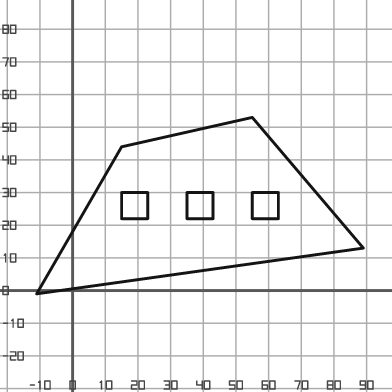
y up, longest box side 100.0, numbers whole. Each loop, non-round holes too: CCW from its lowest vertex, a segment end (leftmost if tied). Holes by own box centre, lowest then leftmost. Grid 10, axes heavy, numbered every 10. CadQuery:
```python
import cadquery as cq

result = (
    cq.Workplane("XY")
    .moveTo(-11.0, -1.0)
    .lineTo(89.0, 13.0)
    .lineTo(55.0, 53.0)
    .lineTo(15.0, 44.0)
    .close()
    .moveTo(15.0, 22.0)
    .lineTo(23.0, 22.0)
    .lineTo(23.0, 30.0)
    .lineTo(15.0, 30.0)
    .close()
    .moveTo(35.0, 22.0)
    .lineTo(43.0, 22.0)
    .lineTo(43.0, 30.0)
    .lineTo(35.0, 30.0)
    .close()
    .moveTo(55.0, 22.0)
    .lineTo(63.0, 22.0)
    .lineTo(63.0, 30.0)
    .lineTo(55.0, 30.0)
    .close()
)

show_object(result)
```